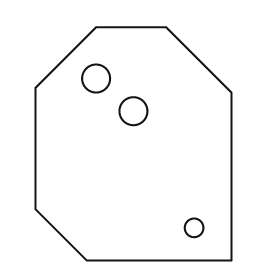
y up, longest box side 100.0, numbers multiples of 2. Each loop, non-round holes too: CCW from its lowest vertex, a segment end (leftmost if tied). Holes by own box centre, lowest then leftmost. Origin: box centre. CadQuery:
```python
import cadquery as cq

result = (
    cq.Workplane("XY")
    .moveTo(-20.0, -50.0)
    .lineTo(42.0, -50.0)
    .lineTo(42.0, 22.0)
    .lineTo(14.0, 50.0)
    .lineTo(-16.0, 50.0)
    .lineTo(-42.0, 24.0)
    .lineTo(-42.0, -28.0)
    .close()
    .moveTo(26.0, -36.0)
    .circle(4.0)
    .moveTo(0.0, 14.0)
    .circle(6.0)
    .moveTo(-16.0, 28.0)
    .circle(6.0)
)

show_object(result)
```